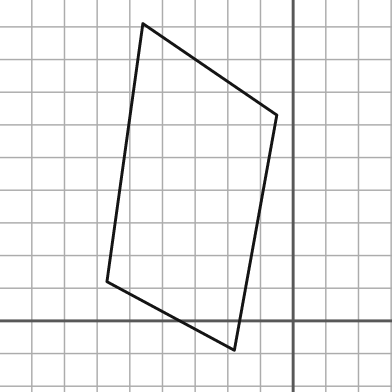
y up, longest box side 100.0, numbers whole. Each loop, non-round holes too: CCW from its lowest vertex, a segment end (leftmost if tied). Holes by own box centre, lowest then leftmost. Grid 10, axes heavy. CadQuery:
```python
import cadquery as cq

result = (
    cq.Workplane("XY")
    .moveTo(-18.0, -9.0)
    .lineTo(-5.0, 63.0)
    .lineTo(-46.0, 91.0)
    .lineTo(-57.0, 12.0)
    .close()
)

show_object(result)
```